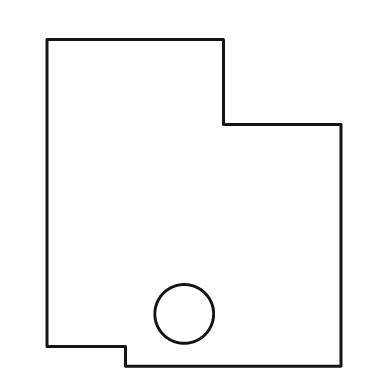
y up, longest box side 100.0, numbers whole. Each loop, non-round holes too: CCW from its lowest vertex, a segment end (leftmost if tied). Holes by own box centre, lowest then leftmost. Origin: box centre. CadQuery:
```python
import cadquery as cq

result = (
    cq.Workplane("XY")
    .moveTo(-21.0, -50.0)
    .lineTo(45.0, -50.0)
    .lineTo(45.0, 24.0)
    .lineTo(9.0, 24.0)
    .lineTo(9.0, 50.0)
    .lineTo(-45.0, 50.0)
    .lineTo(-45.0, -44.0)
    .lineTo(-21.0, -44.0)
    .close()
    .moveTo(-3.0, -34.0)
    .circle(9.0)
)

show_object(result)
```